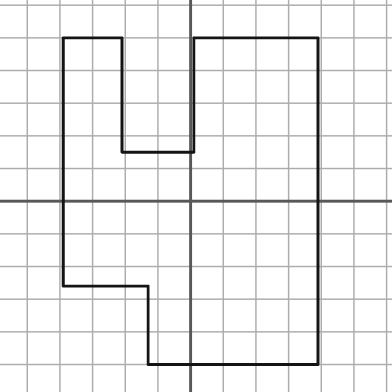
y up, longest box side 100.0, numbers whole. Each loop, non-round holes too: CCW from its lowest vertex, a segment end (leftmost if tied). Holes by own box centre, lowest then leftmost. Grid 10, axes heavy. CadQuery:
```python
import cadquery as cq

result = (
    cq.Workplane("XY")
    .moveTo(-13.0, -50.0)
    .lineTo(39.0, -50.0)
    .lineTo(39.0, 50.0)
    .lineTo(1.0, 50.0)
    .lineTo(1.0, 15.0)
    .lineTo(-21.0, 15.0)
    .lineTo(-21.0, 50.0)
    .lineTo(-39.0, 50.0)
    .lineTo(-39.0, -26.0)
    .lineTo(-13.0, -26.0)
    .close()
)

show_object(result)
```